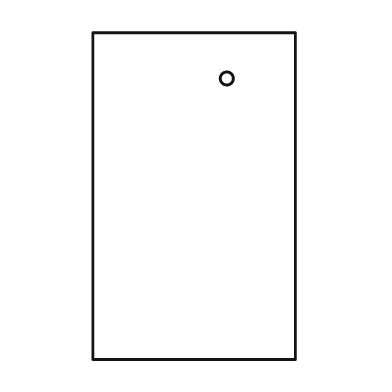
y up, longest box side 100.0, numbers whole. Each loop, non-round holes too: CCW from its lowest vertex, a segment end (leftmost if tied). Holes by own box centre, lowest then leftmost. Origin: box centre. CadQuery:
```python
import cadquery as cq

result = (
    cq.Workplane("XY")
    .moveTo(-31.0, -50.0)
    .lineTo(31.0, -50.0)
    .lineTo(31.0, 50.0)
    .lineTo(-31.0, 50.0)
    .close()
    .moveTo(10.0, 36.0)
    .circle(2.0)
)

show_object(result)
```